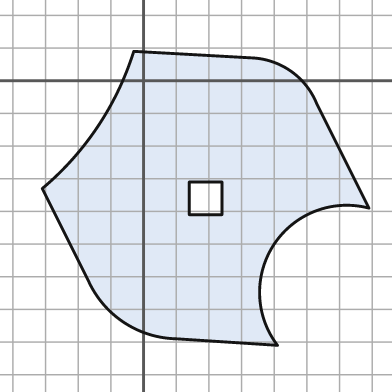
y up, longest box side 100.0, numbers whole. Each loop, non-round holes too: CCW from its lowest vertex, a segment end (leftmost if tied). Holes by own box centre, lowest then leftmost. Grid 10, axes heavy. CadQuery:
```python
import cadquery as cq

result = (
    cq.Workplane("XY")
    .moveTo(41.0, -81.0)
    .threePointArc((40.0, -50.0), (69.0, -39.0))
    .lineTo(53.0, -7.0)
    .threePointArc((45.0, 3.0), (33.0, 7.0))
    .lineTo(-3.0, 9.0)
    .threePointArc((-14.0, -14.0), (-31.0, -33.0))
    .lineTo(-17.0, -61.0)
    .threePointArc((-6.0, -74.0), (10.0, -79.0))
    .close()
    .moveTo(14.0, -41.0)
    .lineTo(24.0, -41.0)
    .lineTo(24.0, -31.0)
    .lineTo(14.0, -31.0)
    .close()
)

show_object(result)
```